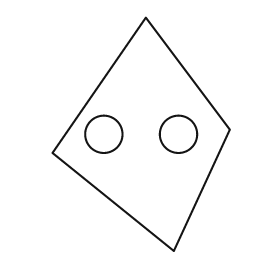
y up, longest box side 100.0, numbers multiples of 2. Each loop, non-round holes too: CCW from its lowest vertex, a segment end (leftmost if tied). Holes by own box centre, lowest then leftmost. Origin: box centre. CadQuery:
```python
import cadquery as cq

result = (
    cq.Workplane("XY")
    .moveTo(14.0, -50.0)
    .lineTo(38.0, 2.0)
    .lineTo(2.0, 50.0)
    .lineTo(-38.0, -8.0)
    .close()
    .moveTo(-16.0, 0.0)
    .circle(8.0)
    .moveTo(16.0, 0.0)
    .circle(8.0)
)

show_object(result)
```